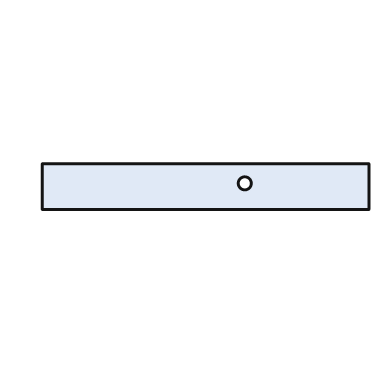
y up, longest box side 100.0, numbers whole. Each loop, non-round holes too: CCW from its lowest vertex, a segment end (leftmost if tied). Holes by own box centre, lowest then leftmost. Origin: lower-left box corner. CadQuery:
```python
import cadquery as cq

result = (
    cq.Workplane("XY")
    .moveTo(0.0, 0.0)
    .lineTo(100.0, 0.0)
    .lineTo(100.0, 14.0)
    .lineTo(0.0, 14.0)
    .close()
    .moveTo(62.0, 8.0)
    .circle(2.0)
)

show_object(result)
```